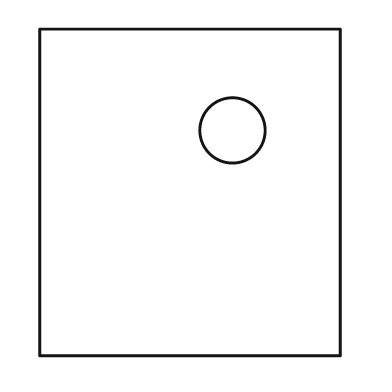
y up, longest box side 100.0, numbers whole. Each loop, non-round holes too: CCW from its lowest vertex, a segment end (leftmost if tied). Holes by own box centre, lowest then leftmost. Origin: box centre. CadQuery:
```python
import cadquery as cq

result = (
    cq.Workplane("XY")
    .moveTo(-46.0, -50.0)
    .lineTo(46.0, -50.0)
    .lineTo(46.0, 50.0)
    .lineTo(-46.0, 50.0)
    .close()
    .moveTo(13.0, 19.0)
    .circle(10.0)
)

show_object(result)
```